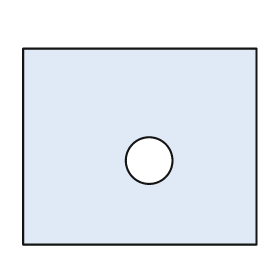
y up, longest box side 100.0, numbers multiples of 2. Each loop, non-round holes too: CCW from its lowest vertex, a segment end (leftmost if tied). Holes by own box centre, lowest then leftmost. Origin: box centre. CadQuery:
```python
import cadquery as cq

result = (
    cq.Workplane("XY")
    .moveTo(-50.0, -42.0)
    .lineTo(50.0, -42.0)
    .lineTo(50.0, 42.0)
    .lineTo(-50.0, 42.0)
    .close()
    .moveTo(4.0, -6.0)
    .circle(10.0)
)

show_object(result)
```